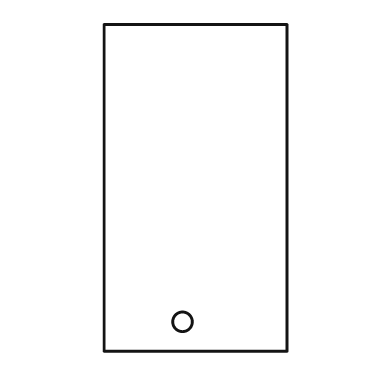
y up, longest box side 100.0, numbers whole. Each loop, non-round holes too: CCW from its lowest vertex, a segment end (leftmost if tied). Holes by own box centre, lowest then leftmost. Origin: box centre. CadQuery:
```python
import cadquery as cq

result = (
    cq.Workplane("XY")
    .moveTo(-28.0, -50.0)
    .lineTo(28.0, -50.0)
    .lineTo(28.0, 50.0)
    .lineTo(-28.0, 50.0)
    .close()
    .moveTo(-4.0, -41.0)
    .circle(3.0)
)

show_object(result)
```